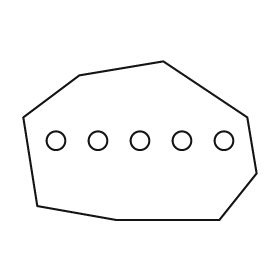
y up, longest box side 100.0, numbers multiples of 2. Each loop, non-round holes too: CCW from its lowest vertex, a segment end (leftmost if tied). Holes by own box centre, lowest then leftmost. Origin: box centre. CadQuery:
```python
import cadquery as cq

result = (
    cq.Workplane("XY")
    .moveTo(-10.0, -34.0)
    .lineTo(34.0, -34.0)
    .lineTo(50.0, -14.0)
    .lineTo(46.0, 10.0)
    .lineTo(10.0, 34.0)
    .lineTo(-26.0, 28.0)
    .lineTo(-50.0, 10.0)
    .lineTo(-44.0, -28.0)
    .close()
    .moveTo(-36.0, 0.0)
    .circle(4.0)
    .moveTo(-18.0, 0.0)
    .circle(4.0)
    .moveTo(0.0, 0.0)
    .circle(4.0)
    .moveTo(18.0, 0.0)
    .circle(4.0)
    .moveTo(36.0, 0.0)
    .circle(4.0)
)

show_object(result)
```